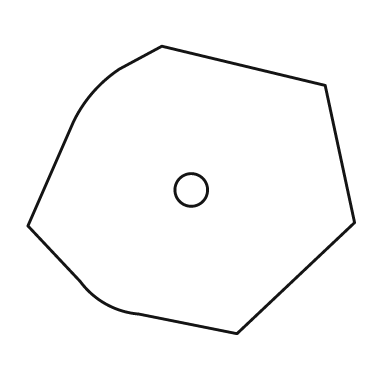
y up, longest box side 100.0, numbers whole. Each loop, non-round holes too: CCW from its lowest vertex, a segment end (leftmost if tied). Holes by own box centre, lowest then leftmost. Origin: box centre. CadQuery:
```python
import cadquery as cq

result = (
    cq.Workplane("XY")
    .moveTo(14.0, -44.0)
    .lineTo(50.0, -10.0)
    .lineTo(41.0, 32.0)
    .lineTo(-9.0, 44.0)
    .lineTo(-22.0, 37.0)
    .threePointArc((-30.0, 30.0), (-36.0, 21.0))
    .lineTo(-50.0, -11.0)
    .lineTo(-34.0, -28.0)
    .threePointArc((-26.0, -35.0), (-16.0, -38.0))
    .close()
    .moveTo(0.0, 0.0)
    .circle(5.0)
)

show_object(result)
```